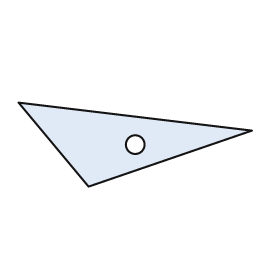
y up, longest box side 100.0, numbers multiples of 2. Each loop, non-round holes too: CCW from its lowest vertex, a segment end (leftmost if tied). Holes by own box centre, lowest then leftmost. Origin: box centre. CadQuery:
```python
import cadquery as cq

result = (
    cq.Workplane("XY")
    .moveTo(-20.0, -18.0)
    .lineTo(50.0, 6.0)
    .lineTo(-50.0, 18.0)
    .close()
    .moveTo(0.0, 0.0)
    .circle(4.0)
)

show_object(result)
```